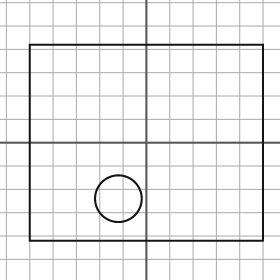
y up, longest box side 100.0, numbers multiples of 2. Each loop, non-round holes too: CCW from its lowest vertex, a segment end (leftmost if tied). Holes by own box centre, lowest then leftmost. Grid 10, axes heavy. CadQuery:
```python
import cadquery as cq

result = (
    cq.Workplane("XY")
    .moveTo(-50.0, -42.0)
    .lineTo(50.0, -42.0)
    .lineTo(50.0, 42.0)
    .lineTo(-50.0, 42.0)
    .close()
    .moveTo(-12.0, -24.0)
    .circle(10.0)
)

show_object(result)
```